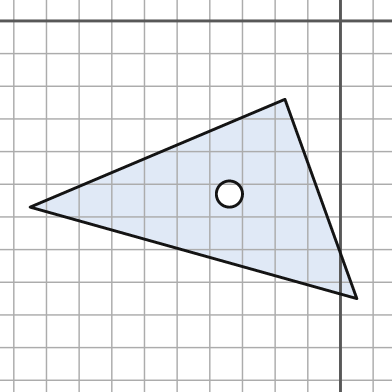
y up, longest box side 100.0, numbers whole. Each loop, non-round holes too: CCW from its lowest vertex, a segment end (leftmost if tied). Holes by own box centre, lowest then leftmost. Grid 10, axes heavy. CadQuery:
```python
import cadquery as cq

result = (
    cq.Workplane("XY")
    .moveTo(5.0, -85.0)
    .lineTo(-17.0, -24.0)
    .lineTo(-95.0, -57.0)
    .close()
    .moveTo(-34.0, -53.0)
    .circle(4.0)
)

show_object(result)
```